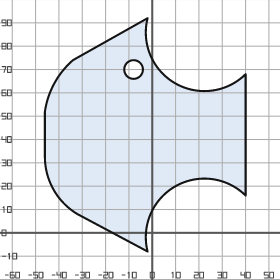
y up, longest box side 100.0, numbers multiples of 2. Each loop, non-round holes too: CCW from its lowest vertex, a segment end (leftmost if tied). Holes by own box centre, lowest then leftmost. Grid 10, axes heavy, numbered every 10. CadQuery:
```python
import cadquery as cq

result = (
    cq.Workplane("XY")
    .moveTo(-2.0, -8.0)
    .threePointArc((10.0, 20.0), (40.0, 16.0))
    .lineTo(40.0, 68.0)
    .threePointArc((10.0, 64.0), (-2.0, 92.0))
    .lineTo(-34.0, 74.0)
    .threePointArc((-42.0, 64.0), (-46.0, 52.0))
    .lineTo(-46.0, 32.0)
    .threePointArc((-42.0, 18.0), (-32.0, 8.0))
    .close()
    .moveTo(-8.0, 70.0)
    .circle(4.0)
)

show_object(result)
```